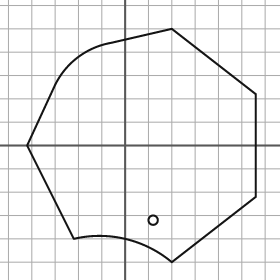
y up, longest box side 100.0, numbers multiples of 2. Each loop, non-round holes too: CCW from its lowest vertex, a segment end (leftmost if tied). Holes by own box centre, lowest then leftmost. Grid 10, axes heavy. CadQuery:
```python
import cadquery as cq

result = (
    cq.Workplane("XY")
    .moveTo(20.0, -50.0)
    .lineTo(56.0, -22.0)
    .lineTo(56.0, 22.0)
    .lineTo(20.0, 50.0)
    .lineTo(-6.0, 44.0)
    .threePointArc((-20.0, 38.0), (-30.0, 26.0))
    .lineTo(-42.0, 0.0)
    .lineTo(-22.0, -40.0)
    .threePointArc((0.0, -40.0), (20.0, -50.0))
    .close()
    .moveTo(12.0, -32.0)
    .circle(2.0)
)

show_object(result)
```